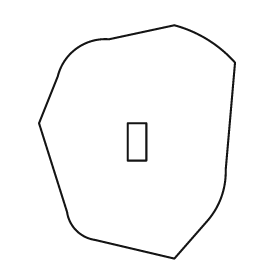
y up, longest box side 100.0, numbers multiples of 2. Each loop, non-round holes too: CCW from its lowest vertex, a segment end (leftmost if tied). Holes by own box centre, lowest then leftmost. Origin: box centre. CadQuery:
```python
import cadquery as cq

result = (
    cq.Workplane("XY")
    .moveTo(16.0, -50.0)
    .lineTo(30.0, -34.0)
    .threePointArc((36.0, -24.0), (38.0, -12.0))
    .lineTo(42.0, 34.0)
    .threePointArc((30.0, 44.0), (16.0, 50.0))
    .lineTo(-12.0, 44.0)
    .threePointArc((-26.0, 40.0), (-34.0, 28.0))
    .lineTo(-42.0, 8.0)
    .lineTo(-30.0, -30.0)
    .threePointArc((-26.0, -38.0), (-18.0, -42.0))
    .close()
    .moveTo(-4.0, -8.0)
    .lineTo(4.0, -8.0)
    .lineTo(4.0, 8.0)
    .lineTo(-4.0, 8.0)
    .close()
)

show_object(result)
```